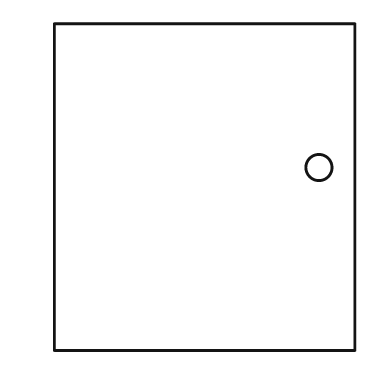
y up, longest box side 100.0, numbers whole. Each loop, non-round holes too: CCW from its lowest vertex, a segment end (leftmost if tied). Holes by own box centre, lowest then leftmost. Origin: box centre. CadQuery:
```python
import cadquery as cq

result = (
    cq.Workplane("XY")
    .moveTo(-46.0, -50.0)
    .lineTo(46.0, -50.0)
    .lineTo(46.0, 50.0)
    .lineTo(-46.0, 50.0)
    .close()
    .moveTo(35.0, 6.0)
    .circle(4.0)
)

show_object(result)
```